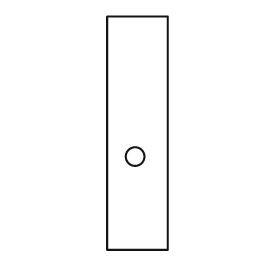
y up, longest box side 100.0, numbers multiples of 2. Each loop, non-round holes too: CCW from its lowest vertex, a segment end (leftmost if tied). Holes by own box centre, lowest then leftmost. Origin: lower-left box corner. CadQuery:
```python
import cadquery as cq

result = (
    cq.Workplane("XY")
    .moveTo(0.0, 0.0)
    .lineTo(26.0, 0.0)
    .lineTo(26.0, 100.0)
    .lineTo(0.0, 100.0)
    .close()
    .moveTo(12.0, 40.0)
    .circle(4.0)
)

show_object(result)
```